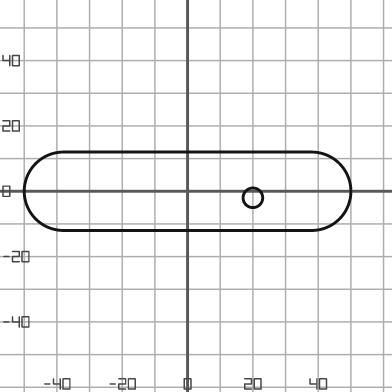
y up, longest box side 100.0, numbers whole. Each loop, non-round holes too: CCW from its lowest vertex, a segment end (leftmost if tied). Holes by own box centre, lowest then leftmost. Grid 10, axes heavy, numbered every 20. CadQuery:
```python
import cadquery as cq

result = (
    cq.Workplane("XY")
    .moveTo(-38.0, -12.0)
    .lineTo(38.0, -12.0)
    .threePointArc((50.0, 0.0), (38.0, 12.0))
    .lineTo(-38.0, 12.0)
    .threePointArc((-50.0, 0.0), (-38.0, -12.0))
    .close()
    .moveTo(20.0, -2.0)
    .circle(3.0)
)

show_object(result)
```